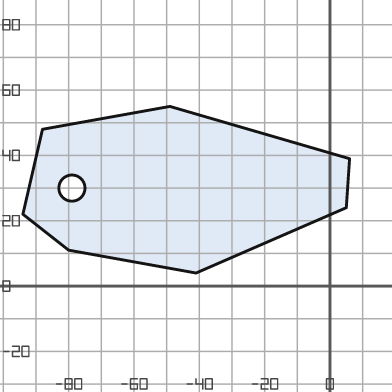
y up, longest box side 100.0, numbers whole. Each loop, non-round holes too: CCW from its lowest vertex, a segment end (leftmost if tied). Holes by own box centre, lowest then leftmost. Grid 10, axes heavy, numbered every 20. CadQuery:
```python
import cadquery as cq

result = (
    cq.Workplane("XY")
    .moveTo(-41.0, 4.0)
    .lineTo(5.0, 24.0)
    .lineTo(6.0, 39.0)
    .lineTo(-49.0, 55.0)
    .lineTo(-88.0, 48.0)
    .lineTo(-94.0, 22.0)
    .lineTo(-80.0, 11.0)
    .close()
    .moveTo(-79.0, 30.0)
    .circle(4.0)
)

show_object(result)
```